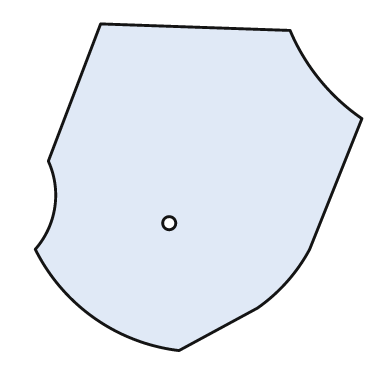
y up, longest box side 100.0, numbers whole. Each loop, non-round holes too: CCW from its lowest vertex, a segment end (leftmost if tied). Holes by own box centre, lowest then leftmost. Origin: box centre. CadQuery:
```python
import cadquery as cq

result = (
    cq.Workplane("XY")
    .moveTo(-6.0, -50.0)
    .lineTo(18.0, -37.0)
    .threePointArc((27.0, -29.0), (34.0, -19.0))
    .lineTo(50.0, 21.0)
    .threePointArc((37.0, 33.0), (28.0, 48.0))
    .lineTo(-30.0, 50.0)
    .lineTo(-46.0, 8.0)
    .threePointArc((-44.0, -6.0), (-50.0, -19.0))
    .threePointArc((-32.0, -40.0), (-6.0, -50.0))
    .close()
    .moveTo(-9.0, -11.0)
    .circle(2.0)
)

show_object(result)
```